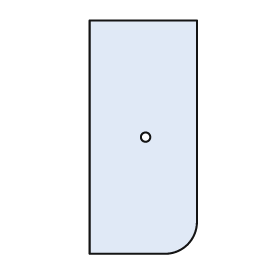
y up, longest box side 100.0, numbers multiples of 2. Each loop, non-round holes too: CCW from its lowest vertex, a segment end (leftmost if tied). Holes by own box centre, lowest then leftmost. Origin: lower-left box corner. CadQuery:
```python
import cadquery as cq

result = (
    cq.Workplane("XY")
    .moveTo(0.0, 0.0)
    .lineTo(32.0, 0.0)
    .threePointArc((42.0, 4.0), (46.0, 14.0))
    .lineTo(46.0, 100.0)
    .lineTo(0.0, 100.0)
    .close()
    .moveTo(24.0, 50.0)
    .circle(2.0)
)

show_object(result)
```